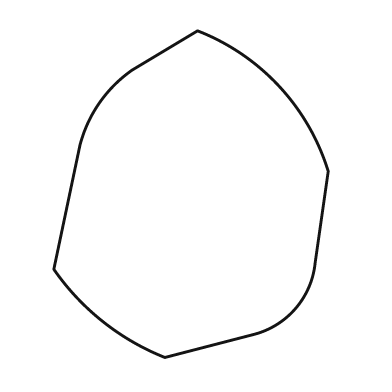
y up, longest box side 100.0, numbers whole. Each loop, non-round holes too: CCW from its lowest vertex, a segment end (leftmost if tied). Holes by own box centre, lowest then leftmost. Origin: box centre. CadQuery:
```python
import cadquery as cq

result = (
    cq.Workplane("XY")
    .moveTo(-8.0, -50.0)
    .lineTo(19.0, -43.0)
    .threePointArc((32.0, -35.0), (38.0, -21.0))
    .lineTo(42.0, 7.0)
    .threePointArc((27.0, 33.0), (2.0, 50.0))
    .lineTo(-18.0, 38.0)
    .threePointArc((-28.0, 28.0), (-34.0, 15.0))
    .lineTo(-42.0, -23.0)
    .threePointArc((-27.0, -39.0), (-8.0, -50.0))
    .close()
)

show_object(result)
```